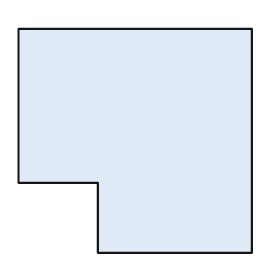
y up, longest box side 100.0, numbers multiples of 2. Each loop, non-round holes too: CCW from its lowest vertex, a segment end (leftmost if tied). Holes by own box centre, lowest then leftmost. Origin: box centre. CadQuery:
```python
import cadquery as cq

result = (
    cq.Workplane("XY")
    .moveTo(-16.0, -48.0)
    .lineTo(50.0, -48.0)
    .lineTo(50.0, 48.0)
    .lineTo(-50.0, 48.0)
    .lineTo(-50.0, -18.0)
    .lineTo(-16.0, -18.0)
    .close()
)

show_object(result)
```